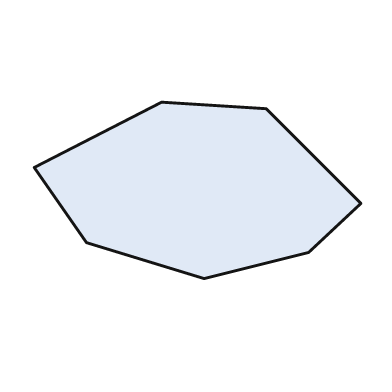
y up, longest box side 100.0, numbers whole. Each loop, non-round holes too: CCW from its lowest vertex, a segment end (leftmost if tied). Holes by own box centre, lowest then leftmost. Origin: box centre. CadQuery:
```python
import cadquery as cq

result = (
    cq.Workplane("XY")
    .moveTo(2.0, -27.0)
    .lineTo(34.0, -19.0)
    .lineTo(50.0, -4.0)
    .lineTo(21.0, 25.0)
    .lineTo(-11.0, 27.0)
    .lineTo(-50.0, 7.0)
    .lineTo(-34.0, -16.0)
    .close()
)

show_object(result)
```